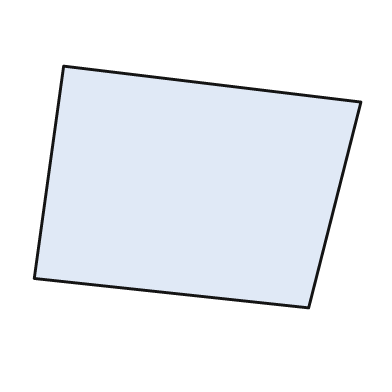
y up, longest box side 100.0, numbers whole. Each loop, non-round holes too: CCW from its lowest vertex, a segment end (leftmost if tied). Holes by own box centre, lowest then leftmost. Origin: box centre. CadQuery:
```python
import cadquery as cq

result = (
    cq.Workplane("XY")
    .moveTo(34.0, -37.0)
    .lineTo(50.0, 26.0)
    .lineTo(-41.0, 37.0)
    .lineTo(-50.0, -28.0)
    .close()
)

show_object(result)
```